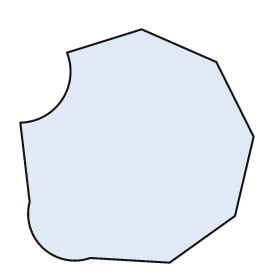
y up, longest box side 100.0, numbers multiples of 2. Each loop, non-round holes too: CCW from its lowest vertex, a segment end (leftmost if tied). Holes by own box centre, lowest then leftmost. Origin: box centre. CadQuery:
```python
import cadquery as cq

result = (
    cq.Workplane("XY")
    .moveTo(14.0, -50.0)
    .lineTo(42.0, -30.0)
    .lineTo(50.0, 4.0)
    .lineTo(34.0, 36.0)
    .lineTo(2.0, 50.0)
    .lineTo(-30.0, 40.0)
    .threePointArc((-32.0, 20.0), (-50.0, 10.0))
    .lineTo(-46.0, -24.0)
    .threePointArc((-40.0, -44.0), (-20.0, -48.0))
    .close()
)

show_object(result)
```